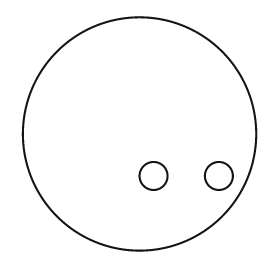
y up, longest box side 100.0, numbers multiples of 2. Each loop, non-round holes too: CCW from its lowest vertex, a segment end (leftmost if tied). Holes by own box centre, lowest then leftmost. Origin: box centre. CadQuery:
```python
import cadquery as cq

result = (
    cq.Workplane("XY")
    .moveTo(0.0, 0.0)
    .circle(50.0)
    .moveTo(6.0, -18.0)
    .circle(6.0)
    .moveTo(34.0, -18.0)
    .circle(6.0)
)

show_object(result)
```